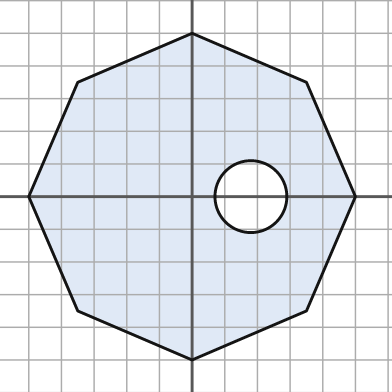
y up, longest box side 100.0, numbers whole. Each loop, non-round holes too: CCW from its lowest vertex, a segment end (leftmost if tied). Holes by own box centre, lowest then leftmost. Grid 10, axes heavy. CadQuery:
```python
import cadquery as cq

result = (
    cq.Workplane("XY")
    .moveTo(0.0, -50.0)
    .lineTo(35.0, -35.0)
    .lineTo(50.0, 0.0)
    .lineTo(35.0, 35.0)
    .lineTo(0.0, 50.0)
    .lineTo(-35.0, 35.0)
    .lineTo(-50.0, 0.0)
    .lineTo(-35.0, -35.0)
    .close()
    .moveTo(18.0, 0.0)
    .circle(11.0)
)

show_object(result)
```